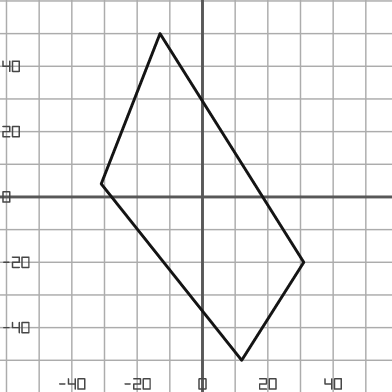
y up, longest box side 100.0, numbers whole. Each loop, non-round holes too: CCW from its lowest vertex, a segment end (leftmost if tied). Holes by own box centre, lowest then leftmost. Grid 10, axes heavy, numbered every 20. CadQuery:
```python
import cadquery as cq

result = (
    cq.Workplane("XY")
    .moveTo(12.0, -50.0)
    .lineTo(31.0, -20.0)
    .lineTo(-13.0, 50.0)
    .lineTo(-31.0, 4.0)
    .close()
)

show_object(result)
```